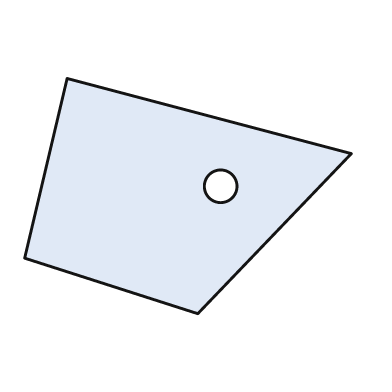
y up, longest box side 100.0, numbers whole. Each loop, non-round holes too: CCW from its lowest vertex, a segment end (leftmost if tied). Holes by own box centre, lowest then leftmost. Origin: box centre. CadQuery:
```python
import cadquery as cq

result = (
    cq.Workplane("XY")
    .moveTo(3.0, -36.0)
    .lineTo(50.0, 13.0)
    .lineTo(-37.0, 36.0)
    .lineTo(-50.0, -19.0)
    .close()
    .moveTo(10.0, 3.0)
    .circle(5.0)
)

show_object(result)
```